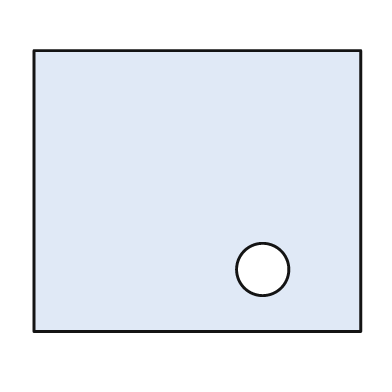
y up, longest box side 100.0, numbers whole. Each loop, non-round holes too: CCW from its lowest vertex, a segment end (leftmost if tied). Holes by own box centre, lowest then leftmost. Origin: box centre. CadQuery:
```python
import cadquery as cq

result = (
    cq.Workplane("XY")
    .moveTo(-50.0, -43.0)
    .lineTo(50.0, -43.0)
    .lineTo(50.0, 43.0)
    .lineTo(-50.0, 43.0)
    .close()
    .moveTo(20.0, -24.0)
    .circle(8.0)
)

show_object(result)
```